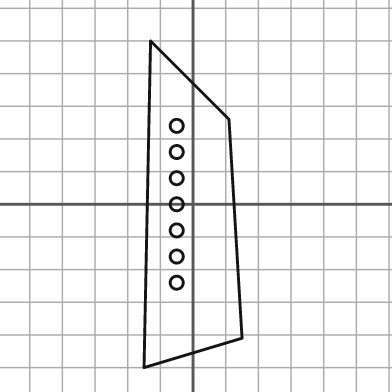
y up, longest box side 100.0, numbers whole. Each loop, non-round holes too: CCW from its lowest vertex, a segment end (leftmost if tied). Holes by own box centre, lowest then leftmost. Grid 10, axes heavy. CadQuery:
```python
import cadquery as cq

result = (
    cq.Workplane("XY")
    .moveTo(-15.0, -50.0)
    .lineTo(15.0, -41.0)
    .lineTo(11.0, 26.0)
    .lineTo(-13.0, 50.0)
    .close()
    .moveTo(-5.0, -24.0)
    .circle(2.0)
    .moveTo(-5.0, -16.0)
    .circle(2.0)
    .moveTo(-5.0, -8.0)
    .circle(2.0)
    .moveTo(-5.0, 0.0)
    .circle(2.0)
    .moveTo(-5.0, 8.0)
    .circle(2.0)
    .moveTo(-5.0, 16.0)
    .circle(2.0)
    .moveTo(-5.0, 24.0)
    .circle(2.0)
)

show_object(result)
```